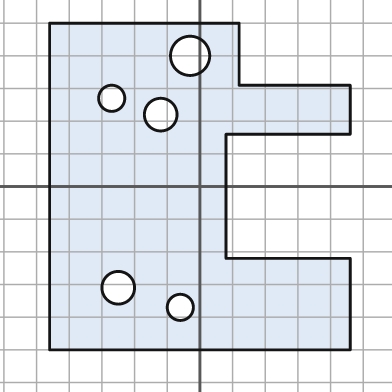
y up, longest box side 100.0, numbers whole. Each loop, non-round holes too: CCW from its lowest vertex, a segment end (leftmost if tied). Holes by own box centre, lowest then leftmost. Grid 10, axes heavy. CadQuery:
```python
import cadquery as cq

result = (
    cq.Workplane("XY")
    .moveTo(-46.0, -50.0)
    .lineTo(46.0, -50.0)
    .lineTo(46.0, -22.0)
    .lineTo(8.0, -22.0)
    .lineTo(8.0, 16.0)
    .lineTo(46.0, 16.0)
    .lineTo(46.0, 31.0)
    .lineTo(12.0, 31.0)
    .lineTo(12.0, 50.0)
    .lineTo(-46.0, 50.0)
    .close()
    .moveTo(-6.0, -37.0)
    .circle(4.0)
    .moveTo(-25.0, -31.0)
    .circle(5.0)
    .moveTo(-12.0, 22.0)
    .circle(5.0)
    .moveTo(-27.0, 27.0)
    .circle(4.0)
    .moveTo(-3.0, 40.0)
    .circle(6.0)
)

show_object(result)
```